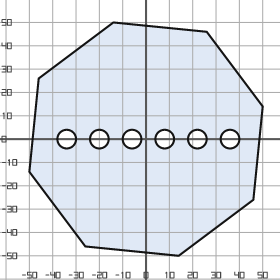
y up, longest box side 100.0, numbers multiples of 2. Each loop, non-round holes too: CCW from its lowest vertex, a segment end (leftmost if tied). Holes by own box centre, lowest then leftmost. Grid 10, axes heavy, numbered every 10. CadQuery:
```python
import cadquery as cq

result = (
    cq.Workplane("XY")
    .moveTo(14.0, -50.0)
    .lineTo(46.0, -26.0)
    .lineTo(50.0, 14.0)
    .lineTo(26.0, 46.0)
    .lineTo(-14.0, 50.0)
    .lineTo(-46.0, 26.0)
    .lineTo(-50.0, -14.0)
    .lineTo(-26.0, -46.0)
    .close()
    .moveTo(-34.0, 0.0)
    .circle(4.0)
    .moveTo(-20.0, 0.0)
    .circle(4.0)
    .moveTo(-6.0, 0.0)
    .circle(4.0)
    .moveTo(8.0, 0.0)
    .circle(4.0)
    .moveTo(22.0, 0.0)
    .circle(4.0)
    .moveTo(36.0, 0.0)
    .circle(4.0)
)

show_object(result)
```